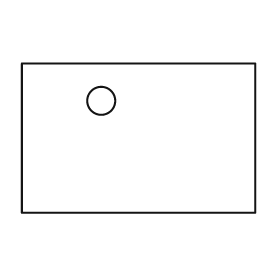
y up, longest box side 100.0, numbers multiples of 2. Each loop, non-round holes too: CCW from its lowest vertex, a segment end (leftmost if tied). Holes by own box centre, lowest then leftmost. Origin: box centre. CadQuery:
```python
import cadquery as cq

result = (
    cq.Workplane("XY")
    .moveTo(-50.0, -32.0)
    .lineTo(50.0, -32.0)
    .lineTo(50.0, 32.0)
    .lineTo(-50.0, 32.0)
    .close()
    .moveTo(-16.0, 16.0)
    .circle(6.0)
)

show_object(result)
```